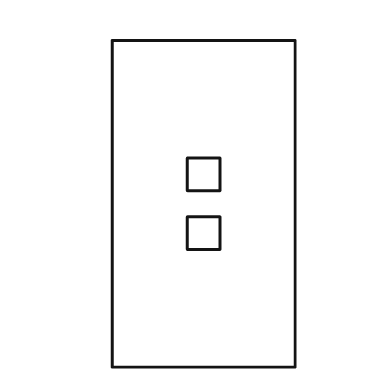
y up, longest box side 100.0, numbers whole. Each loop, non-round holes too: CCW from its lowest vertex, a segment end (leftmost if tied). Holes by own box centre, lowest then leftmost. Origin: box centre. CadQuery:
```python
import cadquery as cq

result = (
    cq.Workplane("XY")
    .moveTo(-28.0, -50.0)
    .lineTo(28.0, -50.0)
    .lineTo(28.0, 50.0)
    .lineTo(-28.0, 50.0)
    .close()
    .moveTo(-5.0, -14.0)
    .lineTo(5.0, -14.0)
    .lineTo(5.0, -4.0)
    .lineTo(-5.0, -4.0)
    .close()
    .moveTo(-5.0, 4.0)
    .lineTo(5.0, 4.0)
    .lineTo(5.0, 14.0)
    .lineTo(-5.0, 14.0)
    .close()
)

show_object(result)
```